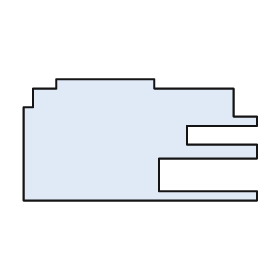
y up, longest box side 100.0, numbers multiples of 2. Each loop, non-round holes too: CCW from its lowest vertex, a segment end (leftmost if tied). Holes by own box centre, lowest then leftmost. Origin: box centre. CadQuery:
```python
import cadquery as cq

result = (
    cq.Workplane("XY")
    .moveTo(-50.0, -26.0)
    .lineTo(50.0, -26.0)
    .lineTo(50.0, -22.0)
    .lineTo(8.0, -22.0)
    .lineTo(8.0, -8.0)
    .lineTo(50.0, -8.0)
    .lineTo(50.0, -2.0)
    .lineTo(20.0, -2.0)
    .lineTo(20.0, 6.0)
    .lineTo(50.0, 6.0)
    .lineTo(50.0, 10.0)
    .lineTo(40.0, 10.0)
    .lineTo(40.0, 22.0)
    .lineTo(6.0, 22.0)
    .lineTo(6.0, 26.0)
    .lineTo(-36.0, 26.0)
    .lineTo(-36.0, 22.0)
    .lineTo(-46.0, 22.0)
    .lineTo(-46.0, 14.0)
    .lineTo(-50.0, 14.0)
    .close()
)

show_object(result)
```